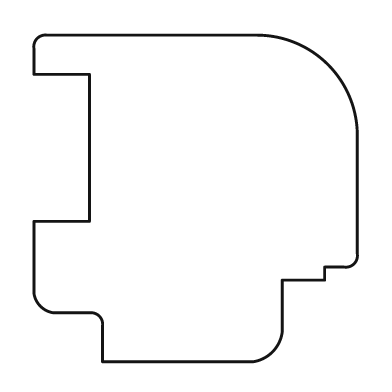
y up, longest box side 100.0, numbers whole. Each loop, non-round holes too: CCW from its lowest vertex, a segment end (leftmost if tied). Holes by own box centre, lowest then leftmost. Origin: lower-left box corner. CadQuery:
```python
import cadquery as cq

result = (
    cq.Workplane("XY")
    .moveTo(21.0, 0.0)
    .lineTo(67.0, 0.0)
    .threePointArc((73.0, 3.0), (76.0, 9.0))
    .lineTo(76.0, 25.0)
    .lineTo(89.0, 25.0)
    .lineTo(89.0, 29.0)
    .lineTo(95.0, 29.0)
    .threePointArc((98.0, 30.0), (99.0, 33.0))
    .lineTo(99.0, 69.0)
    .threePointArc((90.0, 91.0), (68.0, 100.0))
    .lineTo(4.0, 100.0)
    .threePointArc((1.0, 99.0), (0.0, 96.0))
    .lineTo(0.0, 88.0)
    .lineTo(17.0, 88.0)
    .lineTo(17.0, 43.0)
    .lineTo(0.0, 43.0)
    .lineTo(0.0, 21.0)
    .threePointArc((2.0, 17.0), (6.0, 15.0))
    .lineTo(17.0, 15.0)
    .threePointArc((20.0, 14.0), (21.0, 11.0))
    .close()
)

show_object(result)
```